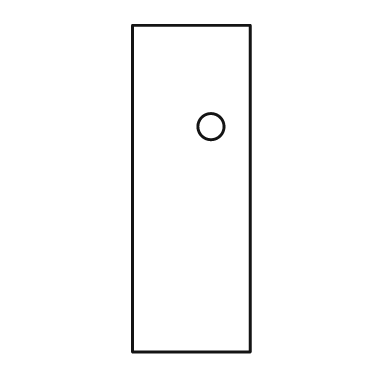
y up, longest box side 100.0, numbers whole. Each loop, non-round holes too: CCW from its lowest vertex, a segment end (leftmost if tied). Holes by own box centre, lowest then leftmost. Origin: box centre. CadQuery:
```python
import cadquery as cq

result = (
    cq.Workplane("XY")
    .moveTo(-18.0, -50.0)
    .lineTo(18.0, -50.0)
    .lineTo(18.0, 50.0)
    .lineTo(-18.0, 50.0)
    .close()
    .moveTo(6.0, 19.0)
    .circle(4.0)
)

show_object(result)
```